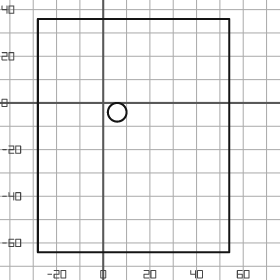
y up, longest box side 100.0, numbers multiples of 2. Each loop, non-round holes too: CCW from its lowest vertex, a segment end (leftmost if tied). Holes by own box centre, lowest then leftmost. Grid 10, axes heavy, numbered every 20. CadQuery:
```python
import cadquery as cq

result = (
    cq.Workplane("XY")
    .moveTo(-28.0, -64.0)
    .lineTo(54.0, -64.0)
    .lineTo(54.0, 36.0)
    .lineTo(-28.0, 36.0)
    .close()
    .moveTo(6.0, -4.0)
    .circle(4.0)
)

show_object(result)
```